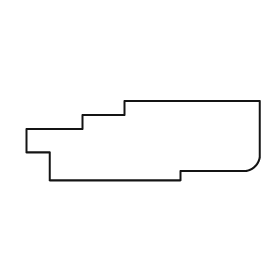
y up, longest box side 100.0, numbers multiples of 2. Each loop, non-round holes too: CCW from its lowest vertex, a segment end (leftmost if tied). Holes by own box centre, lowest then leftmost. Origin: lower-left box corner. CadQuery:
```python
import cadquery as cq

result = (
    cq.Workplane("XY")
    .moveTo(10.0, 0.0)
    .lineTo(66.0, 0.0)
    .lineTo(66.0, 4.0)
    .lineTo(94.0, 4.0)
    .threePointArc((98.0, 6.0), (100.0, 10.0))
    .lineTo(100.0, 34.0)
    .lineTo(42.0, 34.0)
    .lineTo(42.0, 28.0)
    .lineTo(24.0, 28.0)
    .lineTo(24.0, 22.0)
    .lineTo(0.0, 22.0)
    .lineTo(0.0, 12.0)
    .lineTo(10.0, 12.0)
    .close()
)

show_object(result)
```